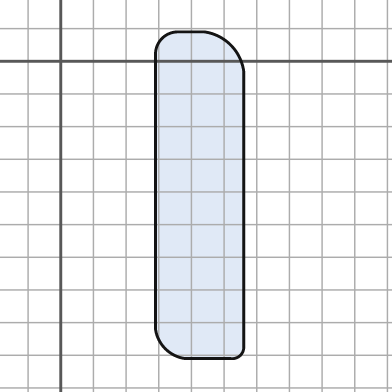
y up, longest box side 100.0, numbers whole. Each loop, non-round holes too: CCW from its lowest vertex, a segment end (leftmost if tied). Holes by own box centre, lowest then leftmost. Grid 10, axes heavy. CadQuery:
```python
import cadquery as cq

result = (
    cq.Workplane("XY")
    .moveTo(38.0, -91.0)
    .lineTo(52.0, -91.0)
    .threePointArc((55.0, -90.0), (56.0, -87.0))
    .lineTo(56.0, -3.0)
    .threePointArc((52.0, 5.0), (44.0, 9.0))
    .lineTo(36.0, 9.0)
    .threePointArc((31.0, 7.0), (29.0, 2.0))
    .lineTo(29.0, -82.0)
    .threePointArc((32.0, -88.0), (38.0, -91.0))
    .close()
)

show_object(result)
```